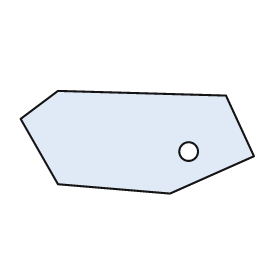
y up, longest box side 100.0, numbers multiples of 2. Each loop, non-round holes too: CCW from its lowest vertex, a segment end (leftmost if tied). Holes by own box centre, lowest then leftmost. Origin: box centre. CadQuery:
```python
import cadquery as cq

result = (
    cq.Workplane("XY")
    .moveTo(14.0, -22.0)
    .lineTo(50.0, -6.0)
    .lineTo(38.0, 20.0)
    .lineTo(-34.0, 22.0)
    .lineTo(-50.0, 10.0)
    .lineTo(-34.0, -18.0)
    .close()
    .moveTo(22.0, -4.0)
    .circle(4.0)
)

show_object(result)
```